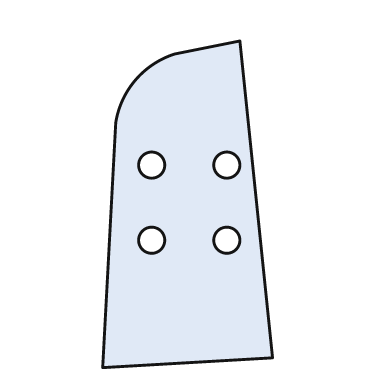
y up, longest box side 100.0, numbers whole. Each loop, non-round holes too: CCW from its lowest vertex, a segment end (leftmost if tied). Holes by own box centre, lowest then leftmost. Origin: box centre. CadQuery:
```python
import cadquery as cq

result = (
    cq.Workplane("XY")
    .moveTo(-26.0, -50.0)
    .lineTo(26.0, -47.0)
    .lineTo(16.0, 50.0)
    .lineTo(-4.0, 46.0)
    .threePointArc((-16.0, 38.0), (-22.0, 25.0))
    .close()
    .moveTo(-11.0, -11.0)
    .circle(4.0)
    .moveTo(12.0, -11.0)
    .circle(4.0)
    .moveTo(-11.0, 12.0)
    .circle(4.0)
    .moveTo(12.0, 12.0)
    .circle(4.0)
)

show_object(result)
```